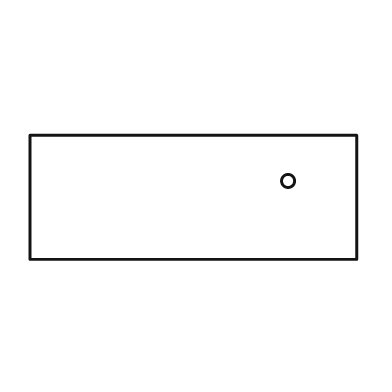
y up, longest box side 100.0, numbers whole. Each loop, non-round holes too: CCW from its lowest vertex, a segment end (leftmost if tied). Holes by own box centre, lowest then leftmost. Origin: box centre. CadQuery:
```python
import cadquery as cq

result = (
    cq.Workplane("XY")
    .moveTo(-50.0, -19.0)
    .lineTo(50.0, -19.0)
    .lineTo(50.0, 19.0)
    .lineTo(-50.0, 19.0)
    .close()
    .moveTo(29.0, 5.0)
    .circle(2.0)
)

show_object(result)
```